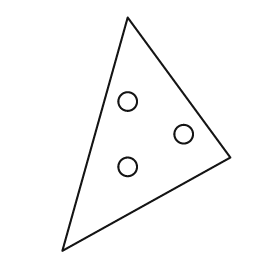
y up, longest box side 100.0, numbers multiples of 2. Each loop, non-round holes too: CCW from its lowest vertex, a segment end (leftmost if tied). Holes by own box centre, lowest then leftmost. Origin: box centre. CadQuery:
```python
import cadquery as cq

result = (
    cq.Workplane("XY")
    .moveTo(-36.0, -50.0)
    .lineTo(36.0, -10.0)
    .lineTo(-8.0, 50.0)
    .close()
    .moveTo(-8.0, -14.0)
    .circle(4.0)
    .moveTo(16.0, 0.0)
    .circle(4.0)
    .moveTo(-8.0, 14.0)
    .circle(4.0)
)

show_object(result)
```